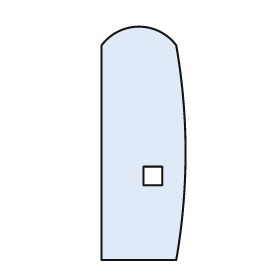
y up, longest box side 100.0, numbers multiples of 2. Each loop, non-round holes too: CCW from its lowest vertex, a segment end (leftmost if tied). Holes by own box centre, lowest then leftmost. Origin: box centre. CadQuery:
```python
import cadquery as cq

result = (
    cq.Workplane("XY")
    .moveTo(-18.0, -50.0)
    .lineTo(14.0, -50.0)
    .threePointArc((18.0, -4.0), (14.0, 42.0))
    .threePointArc((-2.0, 50.0), (-18.0, 42.0))
    .close()
    .moveTo(0.0, -18.0)
    .lineTo(8.0, -18.0)
    .lineTo(8.0, -10.0)
    .lineTo(0.0, -10.0)
    .close()
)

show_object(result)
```